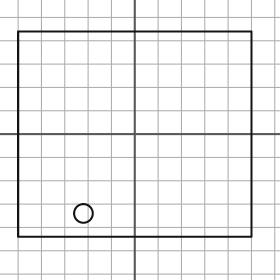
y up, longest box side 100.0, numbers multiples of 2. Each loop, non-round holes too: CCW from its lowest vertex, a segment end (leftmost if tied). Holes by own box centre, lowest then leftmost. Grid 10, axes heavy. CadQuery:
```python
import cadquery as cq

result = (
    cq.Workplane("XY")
    .moveTo(-50.0, -44.0)
    .lineTo(50.0, -44.0)
    .lineTo(50.0, 44.0)
    .lineTo(-50.0, 44.0)
    .close()
    .moveTo(-22.0, -34.0)
    .circle(4.0)
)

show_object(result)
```